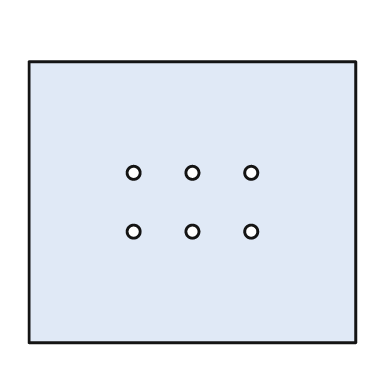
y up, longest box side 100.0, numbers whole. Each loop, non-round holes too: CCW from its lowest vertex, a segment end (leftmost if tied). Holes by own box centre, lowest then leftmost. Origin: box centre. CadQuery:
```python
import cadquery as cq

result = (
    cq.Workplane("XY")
    .moveTo(-50.0, -43.0)
    .lineTo(50.0, -43.0)
    .lineTo(50.0, 43.0)
    .lineTo(-50.0, 43.0)
    .close()
    .moveTo(-18.0, -9.0)
    .circle(2.0)
    .moveTo(0.0, -9.0)
    .circle(2.0)
    .moveTo(18.0, -9.0)
    .circle(2.0)
    .moveTo(-18.0, 9.0)
    .circle(2.0)
    .moveTo(0.0, 9.0)
    .circle(2.0)
    .moveTo(18.0, 9.0)
    .circle(2.0)
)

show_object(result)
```